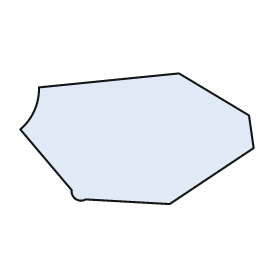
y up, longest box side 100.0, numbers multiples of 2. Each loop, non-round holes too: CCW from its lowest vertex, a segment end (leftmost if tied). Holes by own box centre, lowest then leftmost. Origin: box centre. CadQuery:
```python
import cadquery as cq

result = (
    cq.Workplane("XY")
    .moveTo(14.0, -28.0)
    .lineTo(50.0, -4.0)
    .lineTo(48.0, 10.0)
    .lineTo(18.0, 28.0)
    .lineTo(-42.0, 22.0)
    .threePointArc((-44.0, 12.0), (-50.0, 4.0))
    .lineTo(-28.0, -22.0)
    .threePointArc((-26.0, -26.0), (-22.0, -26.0))
    .close()
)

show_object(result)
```